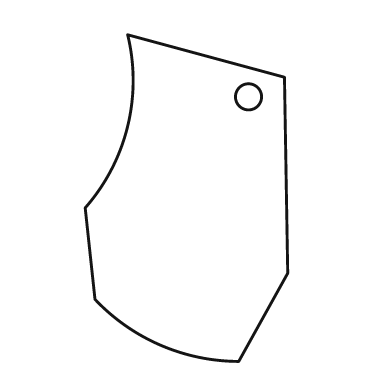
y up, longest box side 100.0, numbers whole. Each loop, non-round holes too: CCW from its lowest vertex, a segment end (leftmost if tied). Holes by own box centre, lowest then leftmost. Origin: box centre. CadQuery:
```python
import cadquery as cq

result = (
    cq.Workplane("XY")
    .moveTo(16.0, -50.0)
    .lineTo(31.0, -23.0)
    .lineTo(30.0, 37.0)
    .lineTo(-18.0, 50.0)
    .threePointArc((-18.0, 22.0), (-31.0, -3.0))
    .lineTo(-28.0, -31.0)
    .threePointArc((-8.0, -45.0), (16.0, -50.0))
    .close()
    .moveTo(19.0, 31.0)
    .circle(4.0)
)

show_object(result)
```